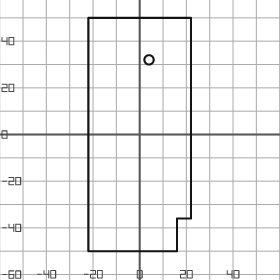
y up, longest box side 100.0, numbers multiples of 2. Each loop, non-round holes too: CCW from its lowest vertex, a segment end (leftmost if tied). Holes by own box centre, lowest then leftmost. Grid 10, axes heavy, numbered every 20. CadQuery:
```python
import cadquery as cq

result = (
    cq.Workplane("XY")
    .moveTo(-22.0, -50.0)
    .lineTo(16.0, -50.0)
    .lineTo(16.0, -36.0)
    .lineTo(22.0, -36.0)
    .lineTo(22.0, 50.0)
    .lineTo(-22.0, 50.0)
    .close()
    .moveTo(4.0, 32.0)
    .circle(2.0)
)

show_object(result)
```